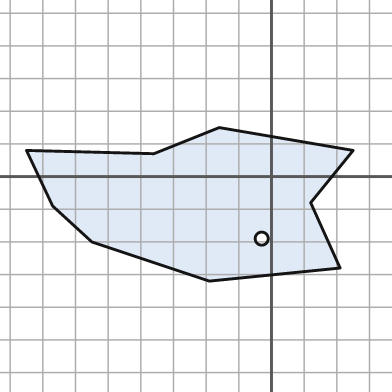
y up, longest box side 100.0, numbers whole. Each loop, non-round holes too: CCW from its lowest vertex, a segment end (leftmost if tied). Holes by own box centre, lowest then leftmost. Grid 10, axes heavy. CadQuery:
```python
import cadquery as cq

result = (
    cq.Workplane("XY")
    .moveTo(-19.0, -32.0)
    .lineTo(21.0, -28.0)
    .lineTo(12.0, -8.0)
    .lineTo(25.0, 8.0)
    .lineTo(-16.0, 15.0)
    .lineTo(-36.0, 7.0)
    .lineTo(-75.0, 8.0)
    .lineTo(-67.0, -9.0)
    .lineTo(-55.0, -20.0)
    .close()
    .moveTo(-3.0, -19.0)
    .circle(2.0)
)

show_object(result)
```